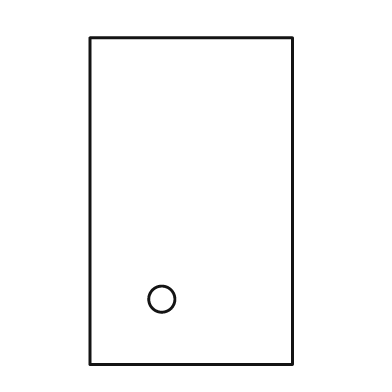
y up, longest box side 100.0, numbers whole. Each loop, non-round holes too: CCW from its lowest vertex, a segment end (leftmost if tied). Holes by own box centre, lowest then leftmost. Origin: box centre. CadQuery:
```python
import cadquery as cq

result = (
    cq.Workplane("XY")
    .moveTo(-31.0, -50.0)
    .lineTo(31.0, -50.0)
    .lineTo(31.0, 50.0)
    .lineTo(-31.0, 50.0)
    .close()
    .moveTo(-9.0, -30.0)
    .circle(4.0)
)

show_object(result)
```